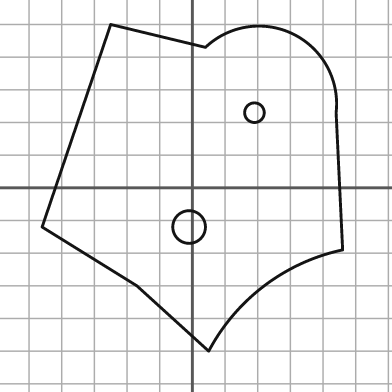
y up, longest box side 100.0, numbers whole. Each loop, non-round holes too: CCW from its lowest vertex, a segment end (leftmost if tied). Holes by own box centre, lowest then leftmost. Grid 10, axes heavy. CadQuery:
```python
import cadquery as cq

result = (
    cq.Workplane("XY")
    .moveTo(5.0, -50.0)
    .threePointArc((22.0, -30.0), (46.0, -19.0))
    .lineTo(44.0, 23.0)
    .threePointArc((31.0, 47.0), (4.0, 43.0))
    .lineTo(-25.0, 50.0)
    .lineTo(-46.0, -12.0)
    .lineTo(-17.0, -30.0)
    .close()
    .moveTo(-1.0, -12.0)
    .circle(5.0)
    .moveTo(19.0, 23.0)
    .circle(3.0)
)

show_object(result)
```